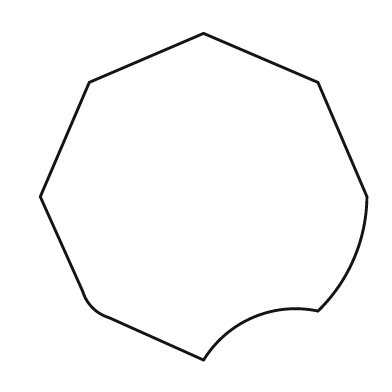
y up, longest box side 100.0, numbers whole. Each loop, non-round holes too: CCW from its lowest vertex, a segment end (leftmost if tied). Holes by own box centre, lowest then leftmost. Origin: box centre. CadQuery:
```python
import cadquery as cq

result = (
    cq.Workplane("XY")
    .moveTo(0.0, -50.0)
    .threePointArc((15.0, -37.0), (35.0, -35.0))
    .threePointArc((46.0, -19.0), (50.0, 0.0))
    .lineTo(35.0, 35.0)
    .lineTo(0.0, 50.0)
    .lineTo(-35.0, 35.0)
    .lineTo(-50.0, 0.0)
    .lineTo(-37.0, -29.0)
    .threePointArc((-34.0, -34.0), (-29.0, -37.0))
    .close()
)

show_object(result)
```